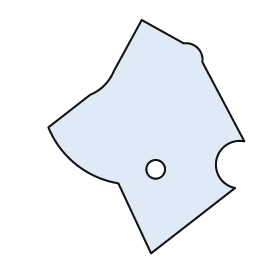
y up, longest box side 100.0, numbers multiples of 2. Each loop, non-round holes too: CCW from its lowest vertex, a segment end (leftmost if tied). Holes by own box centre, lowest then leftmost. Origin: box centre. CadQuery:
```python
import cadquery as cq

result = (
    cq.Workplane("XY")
    .moveTo(2.0, -50.0)
    .lineTo(38.0, -22.0)
    .threePointArc((30.0, -10.0), (42.0, -2.0))
    .lineTo(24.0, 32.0)
    .threePointArc((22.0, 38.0), (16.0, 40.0))
    .lineTo(-2.0, 50.0)
    .lineTo(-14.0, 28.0)
    .threePointArc((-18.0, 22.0), (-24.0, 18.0))
    .lineTo(-42.0, 4.0)
    .threePointArc((-30.0, -12.0), (-12.0, -20.0))
    .close()
    .moveTo(4.0, -14.0)
    .circle(4.0)
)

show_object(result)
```